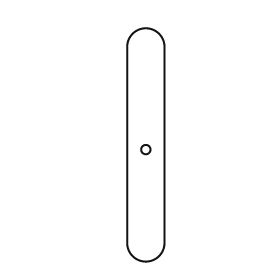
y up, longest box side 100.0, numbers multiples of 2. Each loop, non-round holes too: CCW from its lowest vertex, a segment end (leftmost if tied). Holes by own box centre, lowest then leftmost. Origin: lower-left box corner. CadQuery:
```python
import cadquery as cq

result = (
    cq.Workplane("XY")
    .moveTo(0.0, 8.0)
    .threePointArc((8.0, 0.0), (16.0, 8.0))
    .lineTo(16.0, 92.0)
    .threePointArc((8.0, 100.0), (0.0, 92.0))
    .close()
    .moveTo(8.0, 48.0)
    .circle(2.0)
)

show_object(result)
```